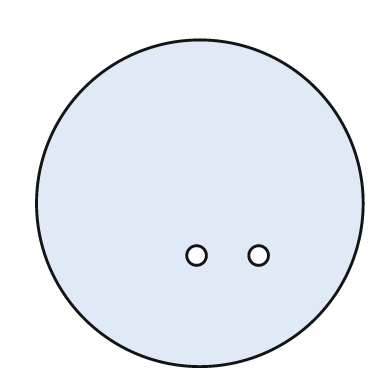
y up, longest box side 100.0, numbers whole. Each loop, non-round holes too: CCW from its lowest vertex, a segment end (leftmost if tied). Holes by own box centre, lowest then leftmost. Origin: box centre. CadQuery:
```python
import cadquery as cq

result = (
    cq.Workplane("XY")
    .moveTo(0.0, 0.0)
    .circle(50.0)
    .moveTo(-1.0, -16.0)
    .circle(3.0)
    .moveTo(18.0, -16.0)
    .circle(3.0)
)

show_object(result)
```